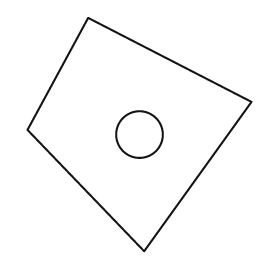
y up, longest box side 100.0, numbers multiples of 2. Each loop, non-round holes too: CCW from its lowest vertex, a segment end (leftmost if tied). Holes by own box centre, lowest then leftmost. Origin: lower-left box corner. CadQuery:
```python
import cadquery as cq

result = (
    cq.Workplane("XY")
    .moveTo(50.0, 0.0)
    .lineTo(96.0, 64.0)
    .lineTo(26.0, 100.0)
    .lineTo(0.0, 52.0)
    .close()
    .moveTo(48.0, 50.0)
    .circle(10.0)
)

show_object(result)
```